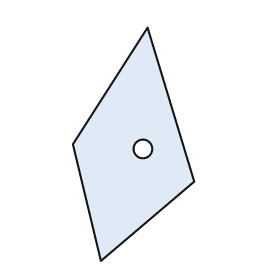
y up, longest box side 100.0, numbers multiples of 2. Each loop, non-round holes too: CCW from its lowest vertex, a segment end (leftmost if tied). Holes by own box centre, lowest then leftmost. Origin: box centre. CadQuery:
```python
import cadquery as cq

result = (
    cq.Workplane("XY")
    .moveTo(-14.0, -50.0)
    .lineTo(26.0, -16.0)
    .lineTo(6.0, 50.0)
    .lineTo(-26.0, 0.0)
    .close()
    .moveTo(4.0, -2.0)
    .circle(4.0)
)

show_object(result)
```